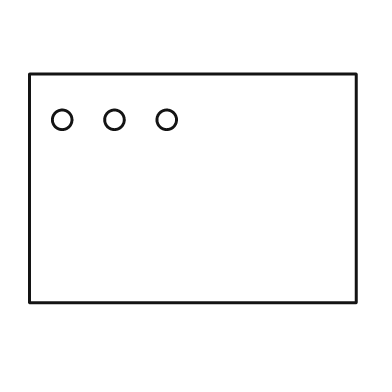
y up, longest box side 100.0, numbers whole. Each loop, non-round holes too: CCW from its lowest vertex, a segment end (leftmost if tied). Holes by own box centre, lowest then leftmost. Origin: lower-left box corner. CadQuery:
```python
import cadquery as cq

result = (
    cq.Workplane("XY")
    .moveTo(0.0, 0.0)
    .lineTo(100.0, 0.0)
    .lineTo(100.0, 70.0)
    .lineTo(0.0, 70.0)
    .close()
    .moveTo(10.0, 56.0)
    .circle(3.0)
    .moveTo(26.0, 56.0)
    .circle(3.0)
    .moveTo(42.0, 56.0)
    .circle(3.0)
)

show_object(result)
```